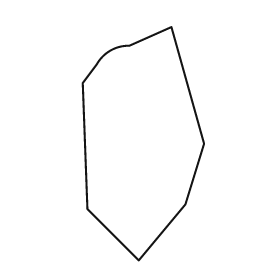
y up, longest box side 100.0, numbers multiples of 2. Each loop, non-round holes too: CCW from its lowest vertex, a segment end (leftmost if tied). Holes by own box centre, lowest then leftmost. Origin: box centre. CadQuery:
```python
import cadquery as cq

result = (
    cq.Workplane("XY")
    .moveTo(-2.0, -50.0)
    .lineTo(18.0, -26.0)
    .lineTo(26.0, 0.0)
    .lineTo(12.0, 50.0)
    .lineTo(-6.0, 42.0)
    .threePointArc((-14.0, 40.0), (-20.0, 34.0))
    .lineTo(-26.0, 26.0)
    .lineTo(-24.0, -28.0)
    .close()
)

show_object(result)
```